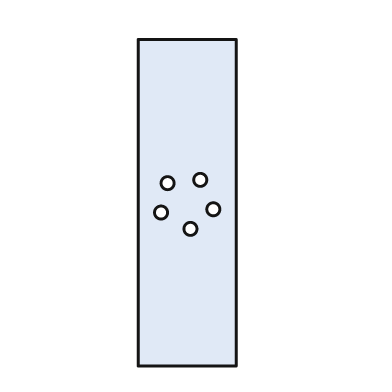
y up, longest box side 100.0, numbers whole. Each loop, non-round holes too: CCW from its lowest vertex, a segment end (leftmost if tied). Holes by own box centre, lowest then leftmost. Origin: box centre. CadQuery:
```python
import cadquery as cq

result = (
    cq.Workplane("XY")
    .moveTo(-15.0, -50.0)
    .lineTo(15.0, -50.0)
    .lineTo(15.0, 50.0)
    .lineTo(-15.0, 50.0)
    .close()
    .moveTo(1.0, -8.0)
    .circle(2.0)
    .moveTo(-8.0, -3.0)
    .circle(2.0)
    .moveTo(8.0, -2.0)
    .circle(2.0)
    .moveTo(-6.0, 6.0)
    .circle(2.0)
    .moveTo(4.0, 7.0)
    .circle(2.0)
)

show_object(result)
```